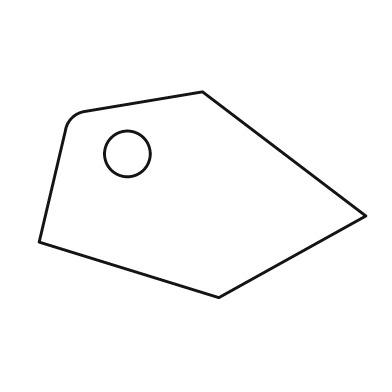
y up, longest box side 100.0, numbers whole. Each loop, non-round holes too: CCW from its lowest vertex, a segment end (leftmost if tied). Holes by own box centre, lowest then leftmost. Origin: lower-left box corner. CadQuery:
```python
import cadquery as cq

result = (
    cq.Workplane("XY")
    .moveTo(55.0, 0.0)
    .lineTo(100.0, 25.0)
    .lineTo(50.0, 63.0)
    .lineTo(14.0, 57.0)
    .threePointArc((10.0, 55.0), (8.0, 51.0))
    .lineTo(0.0, 17.0)
    .close()
    .moveTo(27.0, 44.0)
    .circle(7.0)
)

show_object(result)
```